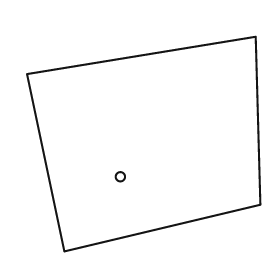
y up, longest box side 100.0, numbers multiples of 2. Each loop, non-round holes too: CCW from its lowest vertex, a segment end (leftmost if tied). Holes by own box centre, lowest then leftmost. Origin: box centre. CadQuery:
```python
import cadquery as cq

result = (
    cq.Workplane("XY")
    .moveTo(-34.0, -46.0)
    .lineTo(50.0, -26.0)
    .lineTo(48.0, 46.0)
    .lineTo(-50.0, 30.0)
    .close()
    .moveTo(-10.0, -14.0)
    .circle(2.0)
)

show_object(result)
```